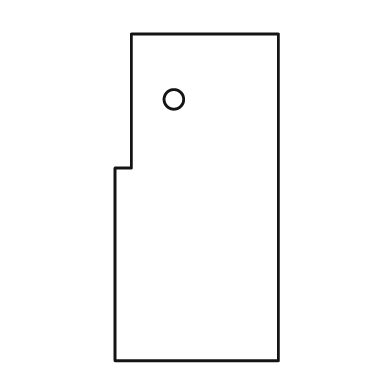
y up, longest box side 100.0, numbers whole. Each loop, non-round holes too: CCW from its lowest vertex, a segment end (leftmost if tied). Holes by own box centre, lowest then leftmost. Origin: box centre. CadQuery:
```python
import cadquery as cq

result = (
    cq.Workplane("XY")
    .moveTo(-25.0, -50.0)
    .lineTo(25.0, -50.0)
    .lineTo(25.0, 50.0)
    .lineTo(-20.0, 50.0)
    .lineTo(-20.0, 9.0)
    .lineTo(-25.0, 9.0)
    .close()
    .moveTo(-7.0, 30.0)
    .circle(3.0)
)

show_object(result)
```